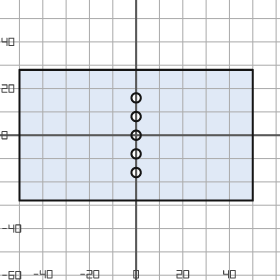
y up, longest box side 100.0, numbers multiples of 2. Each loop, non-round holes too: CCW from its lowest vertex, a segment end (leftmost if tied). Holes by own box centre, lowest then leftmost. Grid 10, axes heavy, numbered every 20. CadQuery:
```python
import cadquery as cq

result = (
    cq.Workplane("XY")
    .moveTo(-50.0, -28.0)
    .lineTo(50.0, -28.0)
    .lineTo(50.0, 28.0)
    .lineTo(-50.0, 28.0)
    .close()
    .moveTo(0.0, -16.0)
    .circle(2.0)
    .moveTo(0.0, -8.0)
    .circle(2.0)
    .moveTo(0.0, 0.0)
    .circle(2.0)
    .moveTo(0.0, 8.0)
    .circle(2.0)
    .moveTo(0.0, 16.0)
    .circle(2.0)
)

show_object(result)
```